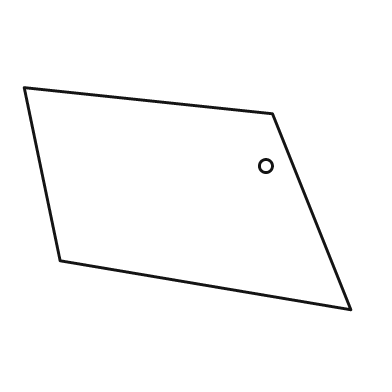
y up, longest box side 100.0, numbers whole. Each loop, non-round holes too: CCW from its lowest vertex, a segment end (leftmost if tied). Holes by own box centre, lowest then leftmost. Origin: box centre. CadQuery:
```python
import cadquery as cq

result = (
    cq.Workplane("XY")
    .moveTo(50.0, -34.0)
    .lineTo(26.0, 26.0)
    .lineTo(-50.0, 34.0)
    .lineTo(-39.0, -19.0)
    .close()
    .moveTo(24.0, 10.0)
    .circle(2.0)
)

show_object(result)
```